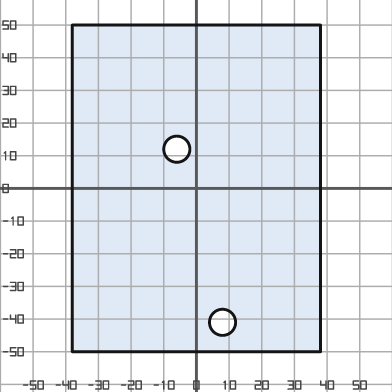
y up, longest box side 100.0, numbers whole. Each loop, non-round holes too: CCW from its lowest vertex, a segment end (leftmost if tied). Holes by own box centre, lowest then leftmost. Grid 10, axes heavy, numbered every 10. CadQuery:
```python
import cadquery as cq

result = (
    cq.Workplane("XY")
    .moveTo(-38.0, -50.0)
    .lineTo(38.0, -50.0)
    .lineTo(38.0, 50.0)
    .lineTo(-38.0, 50.0)
    .close()
    .moveTo(8.0, -41.0)
    .circle(4.0)
    .moveTo(-6.0, 12.0)
    .circle(4.0)
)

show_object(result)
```